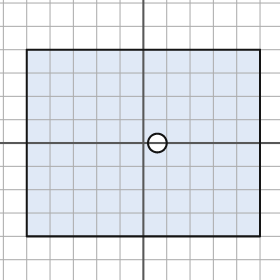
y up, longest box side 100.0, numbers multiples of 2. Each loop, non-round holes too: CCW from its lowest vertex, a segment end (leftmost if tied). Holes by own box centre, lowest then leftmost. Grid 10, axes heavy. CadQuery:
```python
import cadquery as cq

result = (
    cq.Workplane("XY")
    .moveTo(-50.0, -40.0)
    .lineTo(50.0, -40.0)
    .lineTo(50.0, 40.0)
    .lineTo(-50.0, 40.0)
    .close()
    .moveTo(6.0, 0.0)
    .circle(4.0)
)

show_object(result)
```